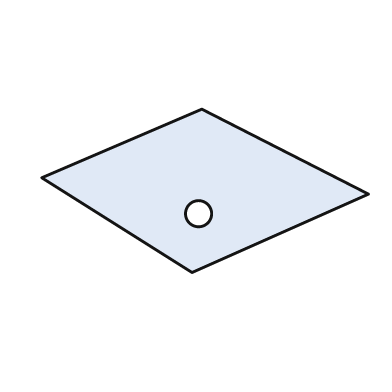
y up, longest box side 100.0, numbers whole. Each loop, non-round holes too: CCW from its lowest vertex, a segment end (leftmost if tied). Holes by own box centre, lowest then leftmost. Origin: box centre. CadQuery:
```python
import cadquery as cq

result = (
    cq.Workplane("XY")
    .moveTo(-4.0, -25.0)
    .lineTo(50.0, -1.0)
    .lineTo(-1.0, 25.0)
    .lineTo(-50.0, 4.0)
    .close()
    .moveTo(-2.0, -7.0)
    .circle(4.0)
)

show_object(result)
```